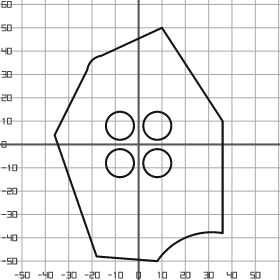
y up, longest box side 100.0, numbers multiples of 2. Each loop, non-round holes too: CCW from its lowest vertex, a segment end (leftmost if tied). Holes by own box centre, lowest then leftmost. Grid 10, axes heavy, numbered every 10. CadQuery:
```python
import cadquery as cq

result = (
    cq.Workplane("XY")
    .moveTo(8.0, -50.0)
    .threePointArc((20.0, -40.0), (36.0, -38.0))
    .lineTo(36.0, 10.0)
    .lineTo(10.0, 50.0)
    .lineTo(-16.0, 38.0)
    .threePointArc((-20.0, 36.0), (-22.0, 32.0))
    .lineTo(-36.0, 4.0)
    .lineTo(-18.0, -48.0)
    .close()
    .moveTo(-8.0, -8.0)
    .circle(6.0)
    .moveTo(8.0, -8.0)
    .circle(6.0)
    .moveTo(-8.0, 8.0)
    .circle(6.0)
    .moveTo(8.0, 8.0)
    .circle(6.0)
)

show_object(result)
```